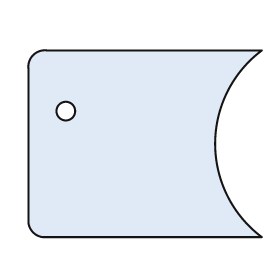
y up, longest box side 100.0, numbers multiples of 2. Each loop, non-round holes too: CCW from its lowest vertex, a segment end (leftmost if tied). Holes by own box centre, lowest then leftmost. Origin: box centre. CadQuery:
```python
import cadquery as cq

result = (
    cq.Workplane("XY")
    .moveTo(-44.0, -40.0)
    .lineTo(50.0, -40.0)
    .threePointArc((30.0, 0.0), (50.0, 40.0))
    .lineTo(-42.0, 40.0)
    .threePointArc((-48.0, 38.0), (-50.0, 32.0))
    .lineTo(-50.0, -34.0)
    .threePointArc((-48.0, -38.0), (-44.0, -40.0))
    .close()
    .moveTo(-34.0, 14.0)
    .circle(4.0)
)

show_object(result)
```